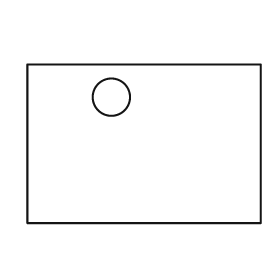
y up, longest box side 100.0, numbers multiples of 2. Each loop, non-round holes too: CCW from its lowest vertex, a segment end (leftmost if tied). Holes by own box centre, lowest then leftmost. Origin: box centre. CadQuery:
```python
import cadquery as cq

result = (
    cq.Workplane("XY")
    .moveTo(-50.0, -34.0)
    .lineTo(50.0, -34.0)
    .lineTo(50.0, 34.0)
    .lineTo(-50.0, 34.0)
    .close()
    .moveTo(-14.0, 20.0)
    .circle(8.0)
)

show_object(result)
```